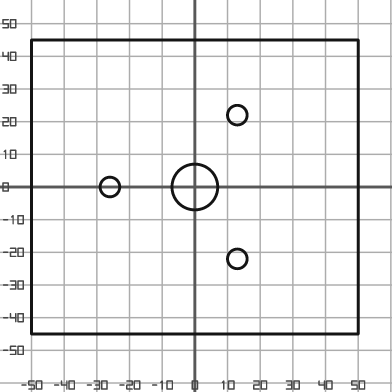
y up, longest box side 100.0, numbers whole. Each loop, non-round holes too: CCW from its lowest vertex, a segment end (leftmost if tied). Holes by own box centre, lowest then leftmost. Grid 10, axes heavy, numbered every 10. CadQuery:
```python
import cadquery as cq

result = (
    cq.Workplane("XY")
    .moveTo(-50.0, -45.0)
    .lineTo(50.0, -45.0)
    .lineTo(50.0, 45.0)
    .lineTo(-50.0, 45.0)
    .close()
    .moveTo(13.0, -22.0)
    .circle(3.0)
    .moveTo(-26.0, 0.0)
    .circle(3.0)
    .moveTo(0.0, 0.0)
    .circle(7.0)
    .moveTo(13.0, 22.0)
    .circle(3.0)
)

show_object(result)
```